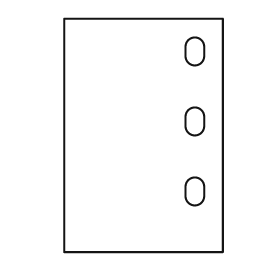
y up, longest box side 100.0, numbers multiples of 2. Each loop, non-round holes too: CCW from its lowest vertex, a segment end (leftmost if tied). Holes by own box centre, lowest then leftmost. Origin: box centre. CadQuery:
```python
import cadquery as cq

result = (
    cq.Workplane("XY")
    .moveTo(-34.0, -50.0)
    .lineTo(34.0, -50.0)
    .lineTo(34.0, 50.0)
    .lineTo(-34.0, 50.0)
    .close()
    .moveTo(18.0, -26.0)
    .threePointArc((22.0, -30.0), (26.0, -26.0))
    .lineTo(26.0, -22.0)
    .threePointArc((22.0, -18.0), (18.0, -22.0))
    .close()
    .moveTo(18.0, 4.0)
    .threePointArc((22.0, 0.0), (26.0, 4.0))
    .lineTo(26.0, 8.0)
    .threePointArc((22.0, 12.0), (18.0, 8.0))
    .close()
    .moveTo(18.0, 34.0)
    .threePointArc((22.0, 30.0), (26.0, 34.0))
    .lineTo(26.0, 38.0)
    .threePointArc((22.0, 42.0), (18.0, 38.0))
    .close()
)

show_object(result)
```